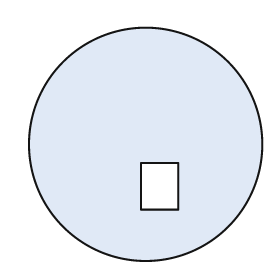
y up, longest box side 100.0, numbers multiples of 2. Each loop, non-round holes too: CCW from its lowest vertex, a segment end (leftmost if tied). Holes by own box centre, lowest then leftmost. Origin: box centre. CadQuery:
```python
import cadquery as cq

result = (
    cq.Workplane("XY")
    .moveTo(0.0, 0.0)
    .circle(50.0)
    .moveTo(-2.0, -28.0)
    .lineTo(14.0, -28.0)
    .lineTo(14.0, -8.0)
    .lineTo(-2.0, -8.0)
    .close()
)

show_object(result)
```